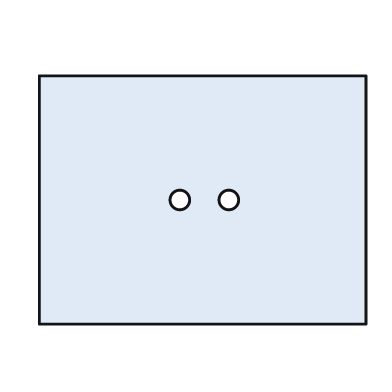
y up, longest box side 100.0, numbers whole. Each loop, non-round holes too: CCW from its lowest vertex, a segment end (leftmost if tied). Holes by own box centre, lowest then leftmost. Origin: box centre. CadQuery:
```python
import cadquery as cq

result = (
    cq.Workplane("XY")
    .moveTo(-50.0, -38.0)
    .lineTo(50.0, -38.0)
    .lineTo(50.0, 38.0)
    .lineTo(-50.0, 38.0)
    .close()
    .moveTo(-7.0, 0.0)
    .circle(3.0)
    .moveTo(8.0, 0.0)
    .circle(3.0)
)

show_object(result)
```